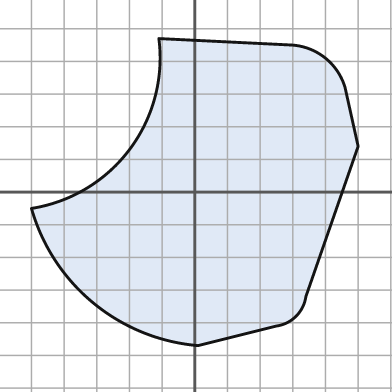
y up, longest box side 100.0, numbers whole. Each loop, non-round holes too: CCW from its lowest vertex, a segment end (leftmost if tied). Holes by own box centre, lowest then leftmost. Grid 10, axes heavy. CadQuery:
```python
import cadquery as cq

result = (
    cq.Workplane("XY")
    .moveTo(1.0, -47.0)
    .lineTo(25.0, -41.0)
    .threePointArc((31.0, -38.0), (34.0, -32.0))
    .lineTo(50.0, 14.0)
    .lineTo(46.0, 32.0)
    .threePointArc((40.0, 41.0), (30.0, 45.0))
    .lineTo(-11.0, 47.0)
    .threePointArc((-20.0, 13.0), (-50.0, -5.0))
    .threePointArc((-31.0, -34.0), (1.0, -47.0))
    .close()
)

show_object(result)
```